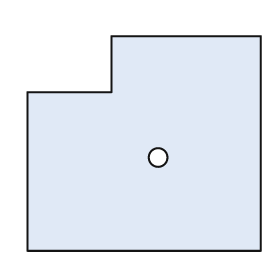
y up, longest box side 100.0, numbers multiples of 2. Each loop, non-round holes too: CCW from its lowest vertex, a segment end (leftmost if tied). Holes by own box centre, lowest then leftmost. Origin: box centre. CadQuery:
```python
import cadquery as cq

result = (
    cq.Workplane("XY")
    .moveTo(-50.0, -46.0)
    .lineTo(50.0, -46.0)
    .lineTo(50.0, 46.0)
    .lineTo(-14.0, 46.0)
    .lineTo(-14.0, 22.0)
    .lineTo(-50.0, 22.0)
    .close()
    .moveTo(6.0, -6.0)
    .circle(4.0)
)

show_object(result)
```